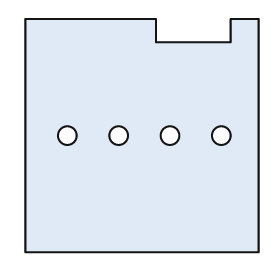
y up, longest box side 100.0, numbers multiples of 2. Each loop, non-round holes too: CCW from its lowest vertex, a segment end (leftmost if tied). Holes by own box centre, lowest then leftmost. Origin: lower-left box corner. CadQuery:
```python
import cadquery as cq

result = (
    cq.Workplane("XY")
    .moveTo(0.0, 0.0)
    .lineTo(100.0, 0.0)
    .lineTo(100.0, 100.0)
    .lineTo(88.0, 100.0)
    .lineTo(88.0, 90.0)
    .lineTo(56.0, 90.0)
    .lineTo(56.0, 100.0)
    .lineTo(0.0, 100.0)
    .close()
    .moveTo(18.0, 50.0)
    .circle(4.0)
    .moveTo(40.0, 50.0)
    .circle(4.0)
    .moveTo(62.0, 50.0)
    .circle(4.0)
    .moveTo(84.0, 50.0)
    .circle(4.0)
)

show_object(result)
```